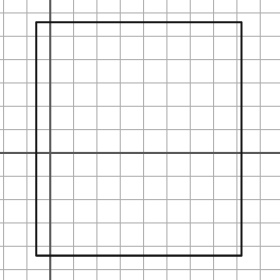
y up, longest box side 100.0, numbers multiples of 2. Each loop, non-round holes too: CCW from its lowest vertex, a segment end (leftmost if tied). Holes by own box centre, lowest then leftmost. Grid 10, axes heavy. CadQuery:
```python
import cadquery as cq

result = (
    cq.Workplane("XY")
    .moveTo(-6.0, -44.0)
    .lineTo(82.0, -44.0)
    .lineTo(82.0, 56.0)
    .lineTo(-6.0, 56.0)
    .close()
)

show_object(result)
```